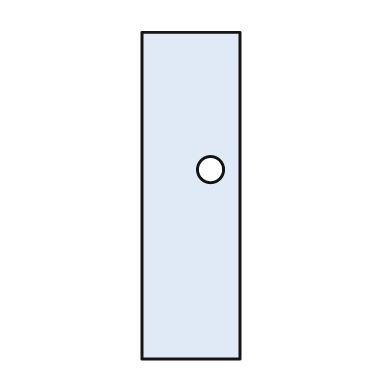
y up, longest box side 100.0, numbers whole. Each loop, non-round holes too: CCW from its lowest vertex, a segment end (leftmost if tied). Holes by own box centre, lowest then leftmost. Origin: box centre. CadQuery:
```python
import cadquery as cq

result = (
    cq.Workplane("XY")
    .moveTo(-15.0, -50.0)
    .lineTo(15.0, -50.0)
    .lineTo(15.0, 50.0)
    .lineTo(-15.0, 50.0)
    .close()
    .moveTo(6.0, 8.0)
    .circle(4.0)
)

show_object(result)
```